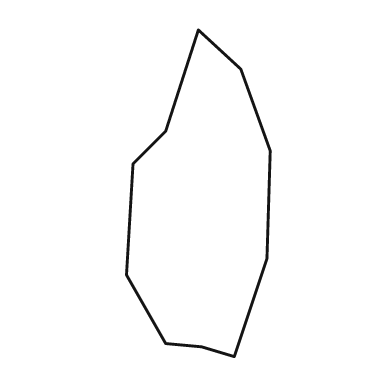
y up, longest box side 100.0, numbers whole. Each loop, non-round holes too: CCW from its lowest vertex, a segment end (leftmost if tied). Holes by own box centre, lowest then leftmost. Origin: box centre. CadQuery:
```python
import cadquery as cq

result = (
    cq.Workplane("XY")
    .moveTo(11.0, -50.0)
    .lineTo(21.0, -20.0)
    .lineTo(22.0, 13.0)
    .lineTo(13.0, 38.0)
    .lineTo(0.0, 50.0)
    .lineTo(-10.0, 19.0)
    .lineTo(-20.0, 9.0)
    .lineTo(-22.0, -25.0)
    .lineTo(-10.0, -46.0)
    .lineTo(1.0, -47.0)
    .close()
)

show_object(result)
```